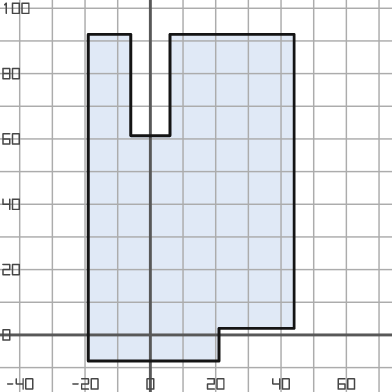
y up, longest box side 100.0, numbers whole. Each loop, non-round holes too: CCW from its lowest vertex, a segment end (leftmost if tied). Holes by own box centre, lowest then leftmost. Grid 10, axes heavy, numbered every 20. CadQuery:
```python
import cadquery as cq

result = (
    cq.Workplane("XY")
    .moveTo(-19.0, -8.0)
    .lineTo(21.0, -8.0)
    .lineTo(21.0, 2.0)
    .lineTo(44.0, 2.0)
    .lineTo(44.0, 92.0)
    .lineTo(6.0, 92.0)
    .lineTo(6.0, 61.0)
    .lineTo(-6.0, 61.0)
    .lineTo(-6.0, 92.0)
    .lineTo(-19.0, 92.0)
    .close()
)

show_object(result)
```